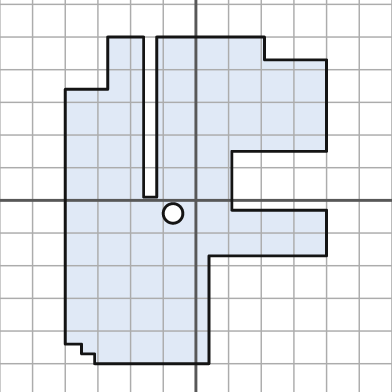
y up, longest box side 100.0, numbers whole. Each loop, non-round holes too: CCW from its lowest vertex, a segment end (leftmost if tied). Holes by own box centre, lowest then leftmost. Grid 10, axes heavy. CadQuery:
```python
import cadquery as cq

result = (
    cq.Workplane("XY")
    .moveTo(-31.0, -50.0)
    .lineTo(4.0, -50.0)
    .lineTo(4.0, -17.0)
    .lineTo(40.0, -17.0)
    .lineTo(40.0, -3.0)
    .lineTo(11.0, -3.0)
    .lineTo(11.0, 15.0)
    .lineTo(40.0, 15.0)
    .lineTo(40.0, 43.0)
    .lineTo(21.0, 43.0)
    .lineTo(21.0, 50.0)
    .lineTo(-12.0, 50.0)
    .lineTo(-12.0, 1.0)
    .lineTo(-16.0, 1.0)
    .lineTo(-16.0, 50.0)
    .lineTo(-27.0, 50.0)
    .lineTo(-27.0, 34.0)
    .lineTo(-40.0, 34.0)
    .lineTo(-40.0, -44.0)
    .lineTo(-35.0, -44.0)
    .lineTo(-35.0, -47.0)
    .lineTo(-31.0, -47.0)
    .close()
    .moveTo(-7.0, -4.0)
    .circle(3.0)
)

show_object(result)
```